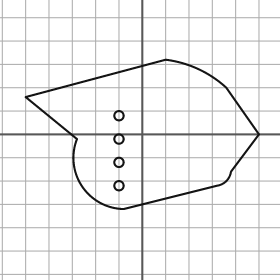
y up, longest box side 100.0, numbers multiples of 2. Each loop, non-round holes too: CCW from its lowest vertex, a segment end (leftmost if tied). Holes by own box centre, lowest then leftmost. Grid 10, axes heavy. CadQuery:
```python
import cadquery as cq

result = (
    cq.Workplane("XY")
    .moveTo(-8.0, -32.0)
    .lineTo(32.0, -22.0)
    .threePointArc((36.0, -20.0), (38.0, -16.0))
    .lineTo(50.0, 0.0)
    .lineTo(36.0, 20.0)
    .threePointArc((24.0, 28.0), (10.0, 32.0))
    .lineTo(-50.0, 16.0)
    .lineTo(-28.0, -2.0)
    .threePointArc((-26.0, -22.0), (-8.0, -32.0))
    .close()
    .moveTo(-10.0, -22.0)
    .circle(2.0)
    .moveTo(-10.0, -12.0)
    .circle(2.0)
    .moveTo(-10.0, -2.0)
    .circle(2.0)
    .moveTo(-10.0, 8.0)
    .circle(2.0)
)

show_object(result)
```